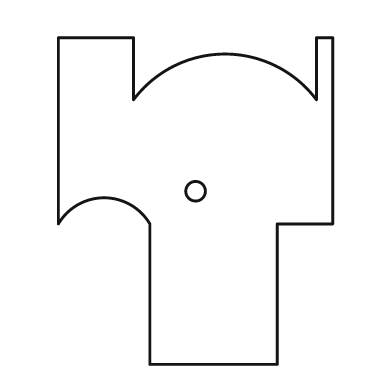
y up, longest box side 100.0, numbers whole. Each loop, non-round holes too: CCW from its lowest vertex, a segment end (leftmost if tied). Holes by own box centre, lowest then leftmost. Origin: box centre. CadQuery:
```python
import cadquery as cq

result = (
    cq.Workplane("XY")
    .moveTo(-14.0, -50.0)
    .lineTo(25.0, -50.0)
    .lineTo(25.0, -7.0)
    .lineTo(42.0, -7.0)
    .lineTo(42.0, 50.0)
    .lineTo(37.0, 50.0)
    .lineTo(37.0, 31.0)
    .threePointArc((9.0, 45.0), (-19.0, 31.0))
    .lineTo(-19.0, 50.0)
    .lineTo(-42.0, 50.0)
    .lineTo(-42.0, -7.0)
    .threePointArc((-28.0, 1.0), (-14.0, -7.0))
    .close()
    .moveTo(0.0, 3.0)
    .circle(3.0)
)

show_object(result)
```